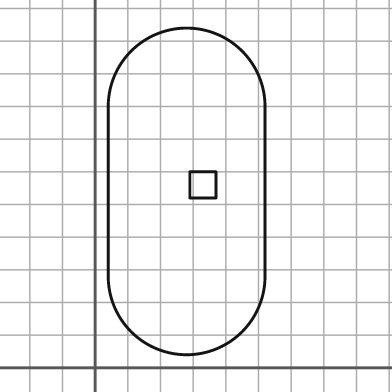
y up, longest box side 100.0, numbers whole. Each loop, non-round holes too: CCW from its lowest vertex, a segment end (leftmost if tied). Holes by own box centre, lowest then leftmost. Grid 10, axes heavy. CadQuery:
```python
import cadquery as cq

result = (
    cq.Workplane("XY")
    .moveTo(4.0, 28.0)
    .threePointArc((28.0, 4.0), (52.0, 28.0))
    .lineTo(52.0, 80.0)
    .threePointArc((28.0, 104.0), (4.0, 80.0))
    .close()
    .moveTo(29.0, 52.0)
    .lineTo(37.0, 52.0)
    .lineTo(37.0, 60.0)
    .lineTo(29.0, 60.0)
    .close()
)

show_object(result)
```